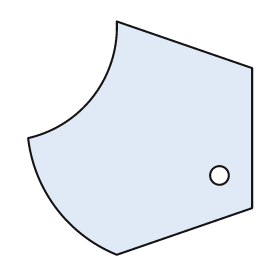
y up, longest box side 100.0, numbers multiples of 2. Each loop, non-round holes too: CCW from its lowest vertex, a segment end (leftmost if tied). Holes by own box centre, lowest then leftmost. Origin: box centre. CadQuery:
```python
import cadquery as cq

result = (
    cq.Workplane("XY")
    .moveTo(-10.0, -50.0)
    .lineTo(48.0, -30.0)
    .lineTo(48.0, 30.0)
    .lineTo(-10.0, 50.0)
    .threePointArc((-20.0, 18.0), (-48.0, 0.0))
    .threePointArc((-36.0, -30.0), (-10.0, -50.0))
    .close()
    .moveTo(34.0, -16.0)
    .circle(4.0)
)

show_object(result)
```